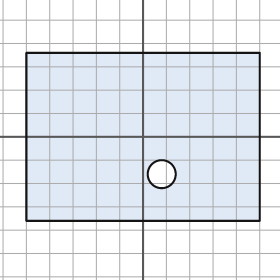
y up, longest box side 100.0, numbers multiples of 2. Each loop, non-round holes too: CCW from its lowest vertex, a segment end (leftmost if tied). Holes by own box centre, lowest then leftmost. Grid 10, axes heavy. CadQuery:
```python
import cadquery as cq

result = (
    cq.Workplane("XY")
    .moveTo(-50.0, -36.0)
    .lineTo(50.0, -36.0)
    .lineTo(50.0, 36.0)
    .lineTo(-50.0, 36.0)
    .close()
    .moveTo(8.0, -16.0)
    .circle(6.0)
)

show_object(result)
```